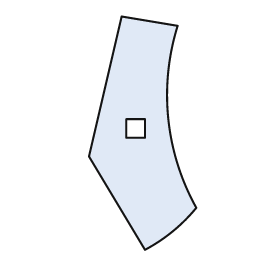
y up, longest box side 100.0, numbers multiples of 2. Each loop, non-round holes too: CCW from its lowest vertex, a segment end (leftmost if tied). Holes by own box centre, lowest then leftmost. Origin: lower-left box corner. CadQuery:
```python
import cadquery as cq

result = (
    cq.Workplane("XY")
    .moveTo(24.0, 0.0)
    .threePointArc((36.0, 8.0), (46.0, 18.0))
    .threePointArc((34.0, 56.0), (38.0, 96.0))
    .lineTo(14.0, 100.0)
    .lineTo(0.0, 40.0)
    .close()
    .moveTo(16.0, 48.0)
    .lineTo(24.0, 48.0)
    .lineTo(24.0, 56.0)
    .lineTo(16.0, 56.0)
    .close()
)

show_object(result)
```